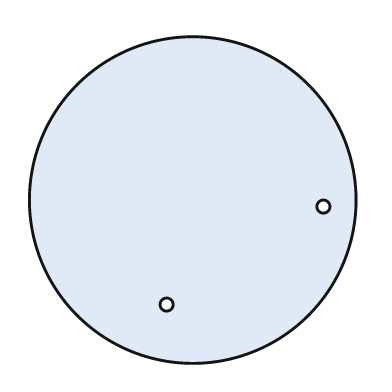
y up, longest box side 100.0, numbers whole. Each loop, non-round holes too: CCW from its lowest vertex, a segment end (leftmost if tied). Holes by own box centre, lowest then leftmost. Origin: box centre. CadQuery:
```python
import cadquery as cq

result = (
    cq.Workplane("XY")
    .moveTo(0.0, 0.0)
    .circle(50.0)
    .moveTo(-8.0, -32.0)
    .circle(2.0)
    .moveTo(40.0, -2.0)
    .circle(2.0)
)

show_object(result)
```